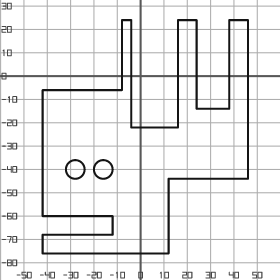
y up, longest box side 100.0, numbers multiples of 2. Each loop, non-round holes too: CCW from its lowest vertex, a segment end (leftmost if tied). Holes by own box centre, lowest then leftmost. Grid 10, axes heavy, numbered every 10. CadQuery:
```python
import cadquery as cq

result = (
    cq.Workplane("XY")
    .moveTo(-42.0, -76.0)
    .lineTo(12.0, -76.0)
    .lineTo(12.0, -44.0)
    .lineTo(46.0, -44.0)
    .lineTo(46.0, 24.0)
    .lineTo(38.0, 24.0)
    .lineTo(38.0, -14.0)
    .lineTo(24.0, -14.0)
    .lineTo(24.0, 24.0)
    .lineTo(16.0, 24.0)
    .lineTo(16.0, -22.0)
    .lineTo(-4.0, -22.0)
    .lineTo(-4.0, 24.0)
    .lineTo(-8.0, 24.0)
    .lineTo(-8.0, -6.0)
    .lineTo(-42.0, -6.0)
    .lineTo(-42.0, -60.0)
    .lineTo(-12.0, -60.0)
    .lineTo(-12.0, -68.0)
    .lineTo(-42.0, -68.0)
    .close()
    .moveTo(-28.0, -40.0)
    .circle(4.0)
    .moveTo(-16.0, -40.0)
    .circle(4.0)
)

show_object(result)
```